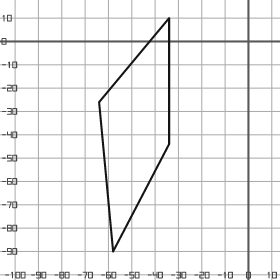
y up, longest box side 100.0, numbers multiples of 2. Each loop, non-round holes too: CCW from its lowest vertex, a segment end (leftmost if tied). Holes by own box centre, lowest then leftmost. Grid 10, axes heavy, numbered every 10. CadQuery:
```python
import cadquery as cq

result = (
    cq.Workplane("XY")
    .moveTo(-58.0, -90.0)
    .lineTo(-34.0, -44.0)
    .lineTo(-34.0, 10.0)
    .lineTo(-64.0, -26.0)
    .close()
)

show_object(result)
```